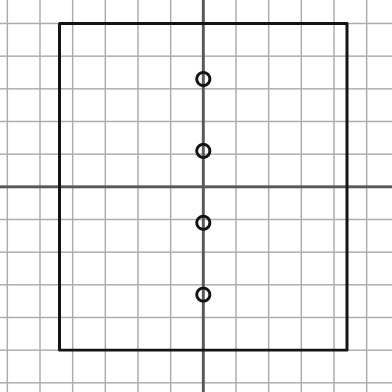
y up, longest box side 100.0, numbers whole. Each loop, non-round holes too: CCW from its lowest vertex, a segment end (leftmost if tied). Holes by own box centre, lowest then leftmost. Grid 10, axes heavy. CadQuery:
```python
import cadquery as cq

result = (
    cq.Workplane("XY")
    .moveTo(-44.0, -50.0)
    .lineTo(44.0, -50.0)
    .lineTo(44.0, 50.0)
    .lineTo(-44.0, 50.0)
    .close()
    .moveTo(0.0, -33.0)
    .circle(2.0)
    .moveTo(0.0, -11.0)
    .circle(2.0)
    .moveTo(0.0, 11.0)
    .circle(2.0)
    .moveTo(0.0, 33.0)
    .circle(2.0)
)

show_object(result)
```